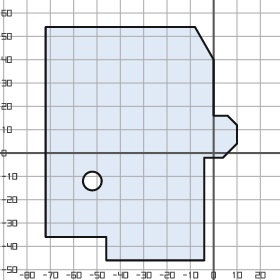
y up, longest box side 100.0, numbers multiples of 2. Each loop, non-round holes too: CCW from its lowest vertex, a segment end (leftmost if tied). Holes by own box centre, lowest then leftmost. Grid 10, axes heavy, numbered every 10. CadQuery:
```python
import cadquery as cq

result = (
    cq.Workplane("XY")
    .moveTo(-46.0, -46.0)
    .lineTo(-4.0, -46.0)
    .lineTo(-4.0, -2.0)
    .lineTo(4.0, -2.0)
    .lineTo(10.0, 4.0)
    .lineTo(10.0, 12.0)
    .lineTo(6.0, 16.0)
    .lineTo(0.0, 16.0)
    .lineTo(0.0, 40.0)
    .lineTo(-8.0, 54.0)
    .lineTo(-72.0, 54.0)
    .lineTo(-72.0, -36.0)
    .lineTo(-46.0, -36.0)
    .close()
    .moveTo(-52.0, -12.0)
    .circle(4.0)
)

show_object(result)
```